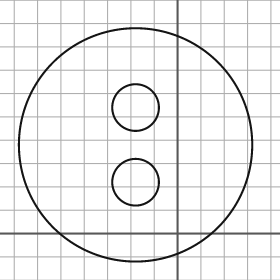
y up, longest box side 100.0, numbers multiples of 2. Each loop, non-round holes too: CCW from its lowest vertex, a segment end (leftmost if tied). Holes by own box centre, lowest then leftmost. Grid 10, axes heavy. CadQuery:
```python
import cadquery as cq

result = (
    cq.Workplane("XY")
    .moveTo(-18.0, 38.0)
    .circle(50.0)
    .moveTo(-18.0, 22.0)
    .circle(10.0)
    .moveTo(-18.0, 54.0)
    .circle(10.0)
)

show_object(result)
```